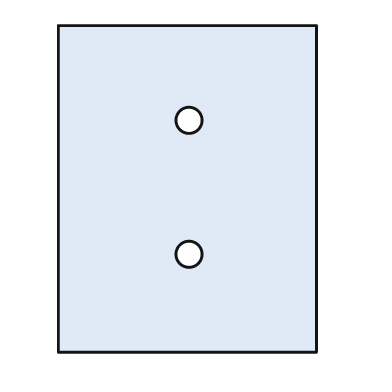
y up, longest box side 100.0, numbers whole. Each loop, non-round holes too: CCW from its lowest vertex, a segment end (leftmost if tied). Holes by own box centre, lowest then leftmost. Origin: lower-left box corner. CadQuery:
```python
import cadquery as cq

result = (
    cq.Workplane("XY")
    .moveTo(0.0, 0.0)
    .lineTo(79.0, 0.0)
    .lineTo(79.0, 100.0)
    .lineTo(0.0, 100.0)
    .close()
    .moveTo(40.0, 30.0)
    .circle(4.0)
    .moveTo(40.0, 71.0)
    .circle(4.0)
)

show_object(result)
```